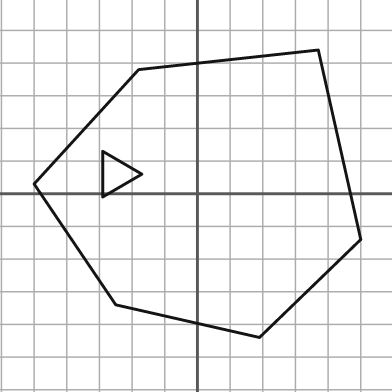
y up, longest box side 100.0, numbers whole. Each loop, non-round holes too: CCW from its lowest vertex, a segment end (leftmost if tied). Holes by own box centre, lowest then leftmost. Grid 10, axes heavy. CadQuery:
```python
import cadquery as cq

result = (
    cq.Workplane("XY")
    .moveTo(19.0, -44.0)
    .lineTo(50.0, -14.0)
    .lineTo(37.0, 44.0)
    .lineTo(-18.0, 38.0)
    .lineTo(-50.0, 3.0)
    .lineTo(-25.0, -34.0)
    .close()
    .moveTo(-29.0, -1.0)
    .lineTo(-17.0, 6.0)
    .lineTo(-29.0, 13.0)
    .close()
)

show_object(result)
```